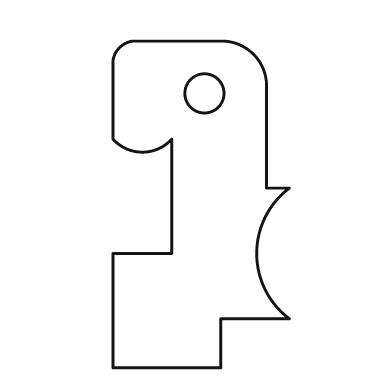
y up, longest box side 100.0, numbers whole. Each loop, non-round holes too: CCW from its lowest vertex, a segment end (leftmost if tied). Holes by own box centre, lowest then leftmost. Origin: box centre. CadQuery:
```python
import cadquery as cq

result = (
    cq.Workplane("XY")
    .moveTo(-27.0, -50.0)
    .lineTo(6.0, -50.0)
    .lineTo(6.0, -35.0)
    .lineTo(27.0, -35.0)
    .threePointArc((17.0, -15.0), (27.0, 5.0))
    .lineTo(20.0, 5.0)
    .lineTo(20.0, 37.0)
    .threePointArc((16.0, 46.0), (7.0, 50.0))
    .lineTo(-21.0, 50.0)
    .threePointArc((-25.0, 48.0), (-27.0, 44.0))
    .lineTo(-27.0, 20.0)
    .threePointArc((-18.0, 16.0), (-9.0, 20.0))
    .lineTo(-9.0, -15.0)
    .lineTo(-27.0, -15.0)
    .close()
    .moveTo(1.0, 34.0)
    .circle(6.0)
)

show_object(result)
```